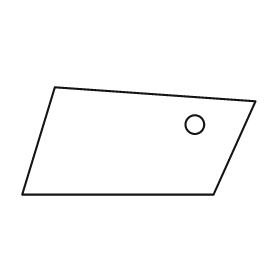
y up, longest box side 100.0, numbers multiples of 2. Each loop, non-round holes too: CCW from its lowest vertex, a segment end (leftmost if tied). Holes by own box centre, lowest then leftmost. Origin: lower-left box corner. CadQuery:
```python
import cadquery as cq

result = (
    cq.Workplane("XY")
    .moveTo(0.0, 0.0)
    .lineTo(82.0, 0.0)
    .lineTo(100.0, 40.0)
    .lineTo(14.0, 46.0)
    .close()
    .moveTo(74.0, 30.0)
    .circle(4.0)
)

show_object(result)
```